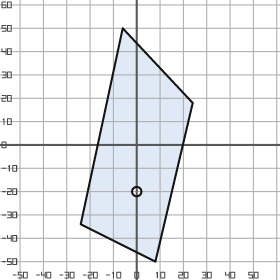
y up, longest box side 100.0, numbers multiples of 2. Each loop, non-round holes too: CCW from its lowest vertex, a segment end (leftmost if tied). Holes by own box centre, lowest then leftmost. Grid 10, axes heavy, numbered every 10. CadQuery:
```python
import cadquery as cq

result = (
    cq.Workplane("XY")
    .moveTo(8.0, -50.0)
    .lineTo(24.0, 18.0)
    .lineTo(-6.0, 50.0)
    .lineTo(-24.0, -34.0)
    .close()
    .moveTo(0.0, -20.0)
    .circle(2.0)
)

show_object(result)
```